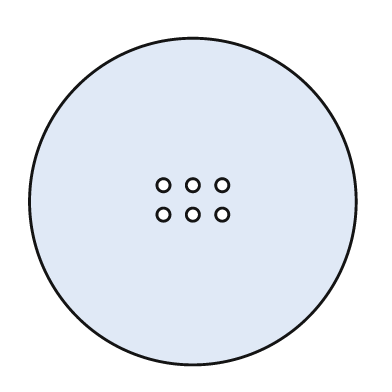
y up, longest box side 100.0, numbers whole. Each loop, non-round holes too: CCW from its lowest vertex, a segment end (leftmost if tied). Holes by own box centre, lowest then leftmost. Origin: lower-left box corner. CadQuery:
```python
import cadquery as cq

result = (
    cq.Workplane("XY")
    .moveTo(50.0, 50.0)
    .circle(50.0)
    .moveTo(41.0, 46.0)
    .circle(2.0)
    .moveTo(50.0, 46.0)
    .circle(2.0)
    .moveTo(59.0, 46.0)
    .circle(2.0)
    .moveTo(41.0, 55.0)
    .circle(2.0)
    .moveTo(50.0, 55.0)
    .circle(2.0)
    .moveTo(59.0, 55.0)
    .circle(2.0)
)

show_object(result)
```